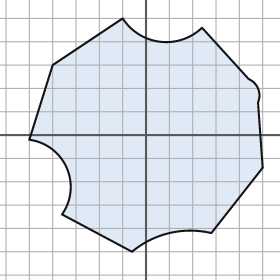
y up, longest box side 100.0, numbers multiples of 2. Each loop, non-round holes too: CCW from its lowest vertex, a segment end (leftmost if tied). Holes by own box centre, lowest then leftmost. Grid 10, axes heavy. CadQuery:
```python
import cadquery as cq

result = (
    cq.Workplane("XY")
    .moveTo(-6.0, -50.0)
    .threePointArc((10.0, -42.0), (28.0, -42.0))
    .lineTo(50.0, -14.0)
    .lineTo(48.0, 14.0)
    .threePointArc((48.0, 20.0), (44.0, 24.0))
    .lineTo(24.0, 46.0)
    .threePointArc((6.0, 40.0), (-10.0, 50.0))
    .lineTo(-40.0, 30.0)
    .lineTo(-50.0, -2.0)
    .threePointArc((-34.0, -14.0), (-36.0, -34.0))
    .close()
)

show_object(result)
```